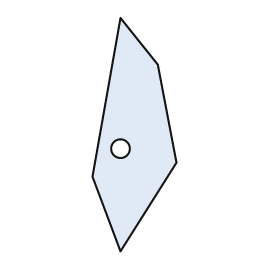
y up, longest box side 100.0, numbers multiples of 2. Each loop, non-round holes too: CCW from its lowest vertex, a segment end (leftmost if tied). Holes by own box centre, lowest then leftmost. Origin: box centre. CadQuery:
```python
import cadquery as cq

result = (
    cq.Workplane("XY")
    .moveTo(-6.0, -50.0)
    .lineTo(18.0, -12.0)
    .lineTo(10.0, 30.0)
    .lineTo(-6.0, 50.0)
    .lineTo(-18.0, -18.0)
    .close()
    .moveTo(-6.0, -6.0)
    .circle(4.0)
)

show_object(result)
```